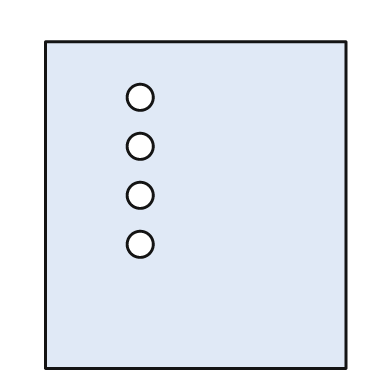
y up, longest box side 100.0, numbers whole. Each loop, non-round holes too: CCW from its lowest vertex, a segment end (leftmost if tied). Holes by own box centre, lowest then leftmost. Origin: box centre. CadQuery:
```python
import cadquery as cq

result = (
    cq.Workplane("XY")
    .moveTo(-46.0, -50.0)
    .lineTo(46.0, -50.0)
    .lineTo(46.0, 50.0)
    .lineTo(-46.0, 50.0)
    .close()
    .moveTo(-17.0, -12.0)
    .circle(4.0)
    .moveTo(-17.0, 3.0)
    .circle(4.0)
    .moveTo(-17.0, 18.0)
    .circle(4.0)
    .moveTo(-17.0, 33.0)
    .circle(4.0)
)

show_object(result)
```